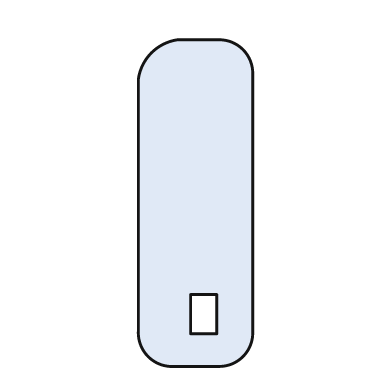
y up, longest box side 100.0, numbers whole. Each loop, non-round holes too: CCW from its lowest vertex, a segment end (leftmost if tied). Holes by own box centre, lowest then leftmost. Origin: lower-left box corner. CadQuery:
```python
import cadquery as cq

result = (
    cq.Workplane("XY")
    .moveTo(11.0, 0.0)
    .lineTo(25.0, 0.0)
    .threePointArc((32.0, 3.0), (35.0, 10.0))
    .lineTo(35.0, 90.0)
    .threePointArc((32.0, 97.0), (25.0, 100.0))
    .lineTo(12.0, 100.0)
    .threePointArc((4.0, 96.0), (0.0, 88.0))
    .lineTo(0.0, 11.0)
    .threePointArc((3.0, 3.0), (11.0, 0.0))
    .close()
    .moveTo(16.0, 10.0)
    .lineTo(24.0, 10.0)
    .lineTo(24.0, 22.0)
    .lineTo(16.0, 22.0)
    .close()
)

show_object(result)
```